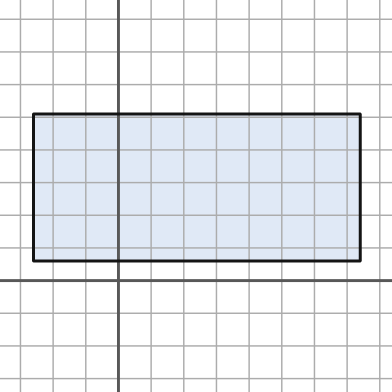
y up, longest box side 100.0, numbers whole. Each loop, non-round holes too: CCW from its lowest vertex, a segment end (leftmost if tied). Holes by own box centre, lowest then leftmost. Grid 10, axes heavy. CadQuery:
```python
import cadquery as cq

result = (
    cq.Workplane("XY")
    .moveTo(-26.0, 6.0)
    .lineTo(74.0, 6.0)
    .lineTo(74.0, 51.0)
    .lineTo(-26.0, 51.0)
    .close()
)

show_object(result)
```